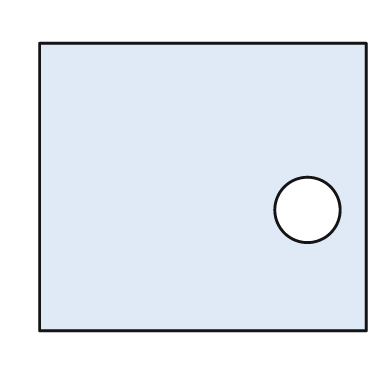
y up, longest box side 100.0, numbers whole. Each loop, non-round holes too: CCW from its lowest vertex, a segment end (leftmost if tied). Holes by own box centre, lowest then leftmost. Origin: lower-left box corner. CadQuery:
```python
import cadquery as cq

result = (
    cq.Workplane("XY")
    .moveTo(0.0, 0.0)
    .lineTo(100.0, 0.0)
    .lineTo(100.0, 88.0)
    .lineTo(0.0, 88.0)
    .close()
    .moveTo(82.0, 37.0)
    .circle(10.0)
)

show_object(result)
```